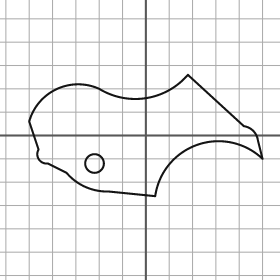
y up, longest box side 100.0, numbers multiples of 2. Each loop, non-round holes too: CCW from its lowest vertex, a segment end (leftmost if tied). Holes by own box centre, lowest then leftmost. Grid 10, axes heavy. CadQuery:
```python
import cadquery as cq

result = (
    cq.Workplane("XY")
    .moveTo(4.0, -26.0)
    .threePointArc((22.0, -4.0), (50.0, -10.0))
    .lineTo(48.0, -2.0)
    .threePointArc((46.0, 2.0), (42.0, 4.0))
    .lineTo(18.0, 26.0)
    .threePointArc((0.0, 16.0), (-20.0, 20.0))
    .threePointArc((-38.0, 20.0), (-50.0, 6.0))
    .lineTo(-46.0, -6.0)
    .threePointArc((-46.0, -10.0), (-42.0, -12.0))
    .lineTo(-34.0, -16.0)
    .threePointArc((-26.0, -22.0), (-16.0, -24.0))
    .close()
    .moveTo(-22.0, -12.0)
    .circle(4.0)
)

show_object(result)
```